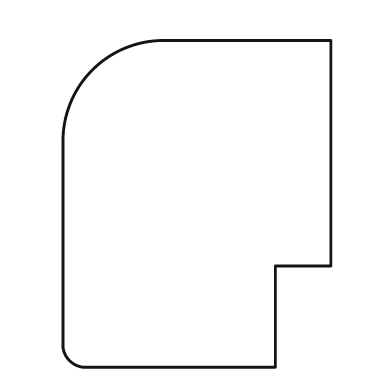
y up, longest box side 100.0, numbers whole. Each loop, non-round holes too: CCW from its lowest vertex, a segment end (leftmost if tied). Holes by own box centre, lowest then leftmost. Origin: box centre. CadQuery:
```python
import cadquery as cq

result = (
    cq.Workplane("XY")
    .moveTo(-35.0, -50.0)
    .lineTo(24.0, -50.0)
    .lineTo(24.0, -19.0)
    .lineTo(41.0, -19.0)
    .lineTo(41.0, 50.0)
    .lineTo(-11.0, 50.0)
    .threePointArc((-32.0, 41.0), (-41.0, 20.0))
    .lineTo(-41.0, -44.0)
    .threePointArc((-39.0, -48.0), (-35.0, -50.0))
    .close()
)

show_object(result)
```